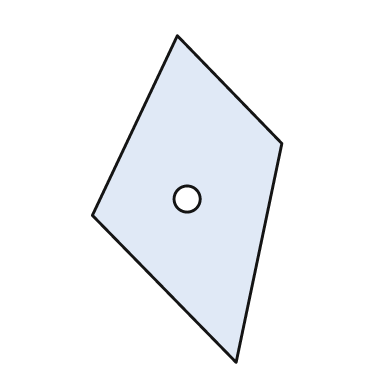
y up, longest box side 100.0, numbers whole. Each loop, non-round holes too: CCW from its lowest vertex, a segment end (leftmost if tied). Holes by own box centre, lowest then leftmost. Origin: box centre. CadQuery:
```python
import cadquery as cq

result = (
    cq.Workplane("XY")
    .moveTo(15.0, -50.0)
    .lineTo(29.0, 17.0)
    .lineTo(-3.0, 50.0)
    .lineTo(-29.0, -5.0)
    .close()
    .moveTo(0.0, 0.0)
    .circle(4.0)
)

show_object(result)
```